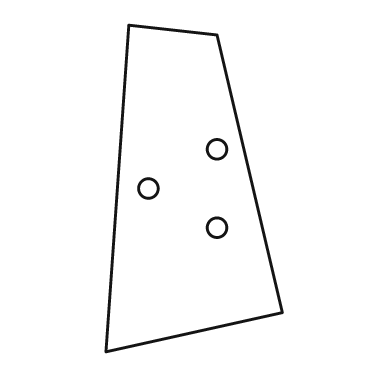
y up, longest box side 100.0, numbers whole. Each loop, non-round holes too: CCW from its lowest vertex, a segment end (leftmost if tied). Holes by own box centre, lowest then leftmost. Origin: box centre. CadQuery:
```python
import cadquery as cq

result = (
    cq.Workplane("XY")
    .moveTo(-27.0, -50.0)
    .lineTo(27.0, -38.0)
    .lineTo(7.0, 47.0)
    .lineTo(-20.0, 50.0)
    .close()
    .moveTo(7.0, -12.0)
    .circle(3.0)
    .moveTo(-14.0, 0.0)
    .circle(3.0)
    .moveTo(7.0, 12.0)
    .circle(3.0)
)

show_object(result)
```